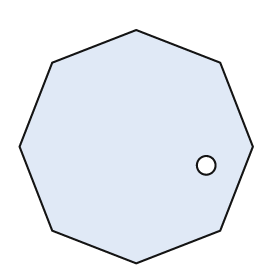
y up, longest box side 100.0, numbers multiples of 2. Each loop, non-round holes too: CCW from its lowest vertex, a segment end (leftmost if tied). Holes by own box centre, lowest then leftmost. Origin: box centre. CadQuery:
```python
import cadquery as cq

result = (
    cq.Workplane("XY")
    .moveTo(0.0, -50.0)
    .lineTo(36.0, -36.0)
    .lineTo(50.0, 0.0)
    .lineTo(36.0, 36.0)
    .lineTo(0.0, 50.0)
    .lineTo(-36.0, 36.0)
    .lineTo(-50.0, 0.0)
    .lineTo(-36.0, -36.0)
    .close()
    .moveTo(30.0, -8.0)
    .circle(4.0)
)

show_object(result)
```